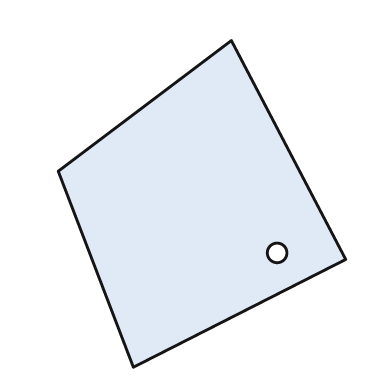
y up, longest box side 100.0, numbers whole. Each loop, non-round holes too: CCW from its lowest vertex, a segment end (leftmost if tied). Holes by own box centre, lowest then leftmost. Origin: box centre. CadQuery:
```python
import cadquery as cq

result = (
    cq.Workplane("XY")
    .moveTo(-21.0, -50.0)
    .lineTo(44.0, -17.0)
    .lineTo(9.0, 50.0)
    .lineTo(-44.0, 10.0)
    .close()
    .moveTo(23.0, -15.0)
    .circle(3.0)
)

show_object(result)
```